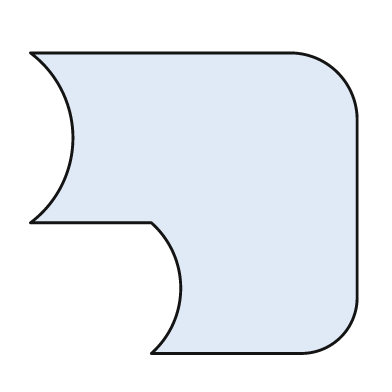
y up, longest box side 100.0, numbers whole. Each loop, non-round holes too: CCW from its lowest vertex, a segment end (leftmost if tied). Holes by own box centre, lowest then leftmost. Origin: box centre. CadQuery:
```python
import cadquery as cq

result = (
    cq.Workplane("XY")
    .moveTo(-13.0, -46.0)
    .lineTo(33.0, -46.0)
    .threePointArc((45.0, -41.0), (50.0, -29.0))
    .lineTo(50.0, 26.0)
    .threePointArc((44.0, 40.0), (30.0, 46.0))
    .lineTo(-50.0, 46.0)
    .threePointArc((-37.0, 20.0), (-50.0, -6.0))
    .lineTo(-13.0, -6.0)
    .threePointArc((-4.0, -26.0), (-13.0, -46.0))
    .close()
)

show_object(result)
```